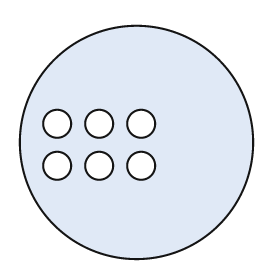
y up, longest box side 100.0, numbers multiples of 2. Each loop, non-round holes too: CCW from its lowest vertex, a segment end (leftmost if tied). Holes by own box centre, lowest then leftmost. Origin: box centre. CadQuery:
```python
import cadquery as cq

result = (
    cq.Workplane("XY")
    .moveTo(0.0, 0.0)
    .circle(50.0)
    .moveTo(-34.0, -10.0)
    .circle(6.0)
    .moveTo(-16.0, -10.0)
    .circle(6.0)
    .moveTo(2.0, -10.0)
    .circle(6.0)
    .moveTo(-34.0, 8.0)
    .circle(6.0)
    .moveTo(-16.0, 8.0)
    .circle(6.0)
    .moveTo(2.0, 8.0)
    .circle(6.0)
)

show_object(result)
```